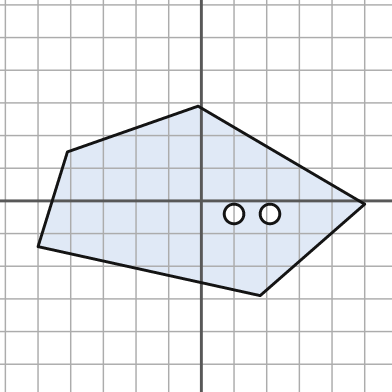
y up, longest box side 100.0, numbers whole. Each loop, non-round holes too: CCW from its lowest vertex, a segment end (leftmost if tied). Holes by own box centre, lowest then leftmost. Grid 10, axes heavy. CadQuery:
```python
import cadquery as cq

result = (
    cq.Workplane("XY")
    .moveTo(18.0, -29.0)
    .lineTo(50.0, -1.0)
    .lineTo(-1.0, 29.0)
    .lineTo(-41.0, 15.0)
    .lineTo(-50.0, -14.0)
    .close()
    .moveTo(10.0, -4.0)
    .circle(3.0)
    .moveTo(21.0, -4.0)
    .circle(3.0)
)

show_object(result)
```